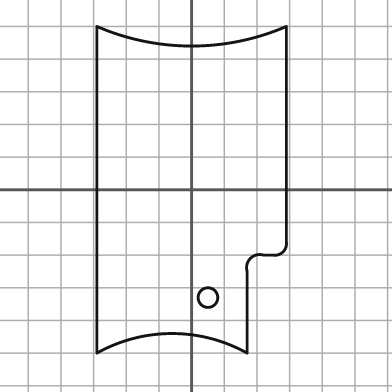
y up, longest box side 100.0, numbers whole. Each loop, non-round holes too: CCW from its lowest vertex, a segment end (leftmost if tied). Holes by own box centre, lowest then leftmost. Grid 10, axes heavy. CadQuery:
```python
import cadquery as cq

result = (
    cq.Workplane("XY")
    .moveTo(-29.0, -50.0)
    .threePointArc((-6.0, -44.0), (17.0, -50.0))
    .lineTo(17.0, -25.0)
    .threePointArc((18.0, -21.0), (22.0, -20.0))
    .lineTo(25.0, -20.0)
    .threePointArc((28.0, -19.0), (29.0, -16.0))
    .lineTo(29.0, 50.0)
    .threePointArc((0.0, 44.0), (-29.0, 50.0))
    .close()
    .moveTo(5.0, -33.0)
    .circle(3.0)
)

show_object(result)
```